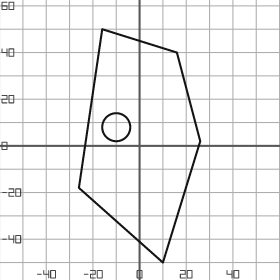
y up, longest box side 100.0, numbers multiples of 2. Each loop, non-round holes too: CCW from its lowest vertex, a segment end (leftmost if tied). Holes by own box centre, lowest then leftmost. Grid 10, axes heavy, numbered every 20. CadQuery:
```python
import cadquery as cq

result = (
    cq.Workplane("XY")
    .moveTo(10.0, -50.0)
    .lineTo(26.0, 2.0)
    .lineTo(16.0, 40.0)
    .lineTo(-16.0, 50.0)
    .lineTo(-26.0, -18.0)
    .close()
    .moveTo(-10.0, 8.0)
    .circle(6.0)
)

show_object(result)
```